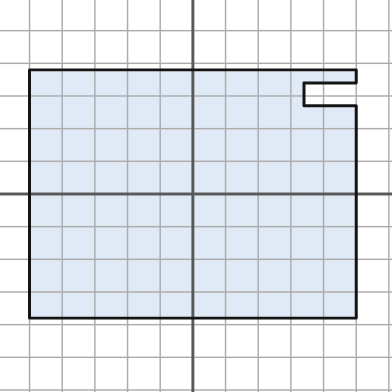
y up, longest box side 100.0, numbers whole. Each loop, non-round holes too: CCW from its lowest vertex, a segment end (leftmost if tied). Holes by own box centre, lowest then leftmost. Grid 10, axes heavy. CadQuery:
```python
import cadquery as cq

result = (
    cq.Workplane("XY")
    .moveTo(-50.0, -38.0)
    .lineTo(50.0, -38.0)
    .lineTo(50.0, 27.0)
    .lineTo(34.0, 27.0)
    .lineTo(34.0, 34.0)
    .lineTo(50.0, 34.0)
    .lineTo(50.0, 38.0)
    .lineTo(-50.0, 38.0)
    .close()
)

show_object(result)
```